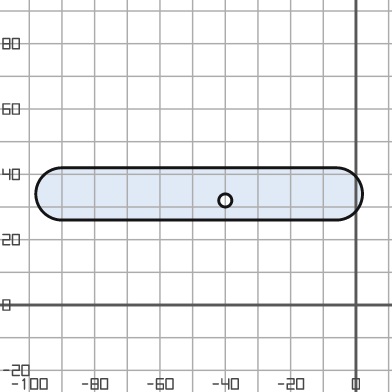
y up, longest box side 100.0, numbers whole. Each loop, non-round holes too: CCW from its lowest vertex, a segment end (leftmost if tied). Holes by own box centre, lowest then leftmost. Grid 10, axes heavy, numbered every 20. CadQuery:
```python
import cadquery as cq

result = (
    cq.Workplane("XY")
    .moveTo(-90.0, 26.0)
    .lineTo(-6.0, 26.0)
    .threePointArc((2.0, 34.0), (-6.0, 42.0))
    .lineTo(-90.0, 42.0)
    .threePointArc((-98.0, 34.0), (-90.0, 26.0))
    .close()
    .moveTo(-40.0, 32.0)
    .circle(2.0)
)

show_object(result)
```